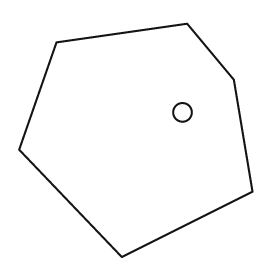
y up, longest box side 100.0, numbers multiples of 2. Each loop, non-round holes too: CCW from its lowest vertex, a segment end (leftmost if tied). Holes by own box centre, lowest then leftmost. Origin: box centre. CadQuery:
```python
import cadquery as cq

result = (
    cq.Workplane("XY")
    .moveTo(-6.0, -50.0)
    .lineTo(50.0, -22.0)
    .lineTo(42.0, 26.0)
    .lineTo(22.0, 50.0)
    .lineTo(-34.0, 42.0)
    .lineTo(-50.0, -4.0)
    .close()
    .moveTo(20.0, 12.0)
    .circle(4.0)
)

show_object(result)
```